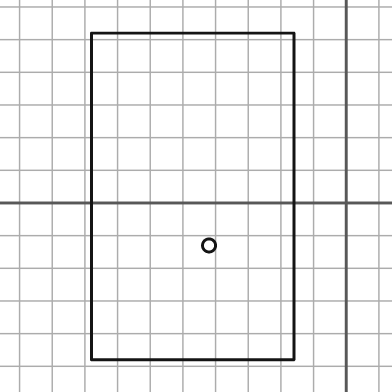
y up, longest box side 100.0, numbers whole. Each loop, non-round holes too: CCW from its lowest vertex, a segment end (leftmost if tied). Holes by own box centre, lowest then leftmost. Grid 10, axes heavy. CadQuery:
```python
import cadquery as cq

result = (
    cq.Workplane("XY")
    .moveTo(-78.0, -48.0)
    .lineTo(-16.0, -48.0)
    .lineTo(-16.0, 52.0)
    .lineTo(-78.0, 52.0)
    .close()
    .moveTo(-42.0, -13.0)
    .circle(2.0)
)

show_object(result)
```